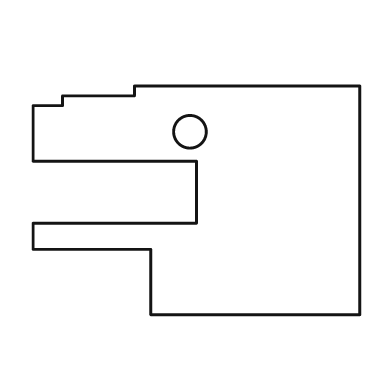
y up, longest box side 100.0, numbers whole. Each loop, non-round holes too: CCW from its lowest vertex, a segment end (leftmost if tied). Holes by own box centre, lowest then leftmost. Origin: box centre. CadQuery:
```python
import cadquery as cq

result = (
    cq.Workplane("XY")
    .moveTo(-14.0, -35.0)
    .lineTo(50.0, -35.0)
    .lineTo(50.0, 35.0)
    .lineTo(-19.0, 35.0)
    .lineTo(-19.0, 32.0)
    .lineTo(-41.0, 32.0)
    .lineTo(-41.0, 29.0)
    .lineTo(-50.0, 29.0)
    .lineTo(-50.0, 12.0)
    .lineTo(0.0, 12.0)
    .lineTo(0.0, -7.0)
    .lineTo(-50.0, -7.0)
    .lineTo(-50.0, -15.0)
    .lineTo(-14.0, -15.0)
    .close()
    .moveTo(-2.0, 21.0)
    .circle(5.0)
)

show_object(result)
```